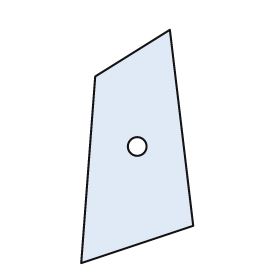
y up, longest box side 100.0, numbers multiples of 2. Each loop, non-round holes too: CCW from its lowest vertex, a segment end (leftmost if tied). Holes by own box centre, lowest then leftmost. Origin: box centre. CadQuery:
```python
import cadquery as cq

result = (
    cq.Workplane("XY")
    .moveTo(-24.0, -50.0)
    .lineTo(24.0, -34.0)
    .lineTo(14.0, 50.0)
    .lineTo(-18.0, 30.0)
    .close()
    .moveTo(0.0, 0.0)
    .circle(4.0)
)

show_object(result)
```